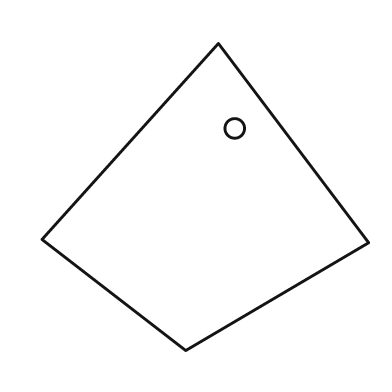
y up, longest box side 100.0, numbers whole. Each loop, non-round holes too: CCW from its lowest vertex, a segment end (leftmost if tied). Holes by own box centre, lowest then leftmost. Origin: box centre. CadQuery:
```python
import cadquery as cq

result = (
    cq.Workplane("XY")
    .moveTo(-6.0, -47.0)
    .lineTo(50.0, -14.0)
    .lineTo(4.0, 47.0)
    .lineTo(-50.0, -13.0)
    .close()
    .moveTo(9.0, 21.0)
    .circle(3.0)
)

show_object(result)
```